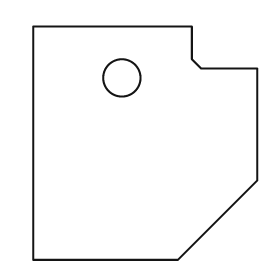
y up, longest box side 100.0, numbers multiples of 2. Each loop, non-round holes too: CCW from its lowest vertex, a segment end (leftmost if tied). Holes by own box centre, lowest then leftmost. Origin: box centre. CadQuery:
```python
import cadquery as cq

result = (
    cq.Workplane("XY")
    .moveTo(-48.0, -50.0)
    .lineTo(14.0, -50.0)
    .lineTo(48.0, -16.0)
    .lineTo(48.0, 32.0)
    .lineTo(24.0, 32.0)
    .lineTo(20.0, 36.0)
    .lineTo(20.0, 50.0)
    .lineTo(-48.0, 50.0)
    .close()
    .moveTo(-10.0, 28.0)
    .circle(8.0)
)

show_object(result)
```